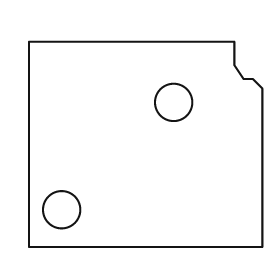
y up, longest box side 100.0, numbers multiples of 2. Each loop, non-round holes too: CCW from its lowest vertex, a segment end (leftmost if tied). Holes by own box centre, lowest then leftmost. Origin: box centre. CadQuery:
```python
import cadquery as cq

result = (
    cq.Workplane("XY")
    .moveTo(-50.0, -44.0)
    .lineTo(50.0, -44.0)
    .lineTo(50.0, 24.0)
    .lineTo(46.0, 28.0)
    .lineTo(42.0, 28.0)
    .lineTo(38.0, 34.0)
    .lineTo(38.0, 44.0)
    .lineTo(-50.0, 44.0)
    .close()
    .moveTo(-36.0, -28.0)
    .circle(8.0)
    .moveTo(12.0, 18.0)
    .circle(8.0)
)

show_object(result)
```